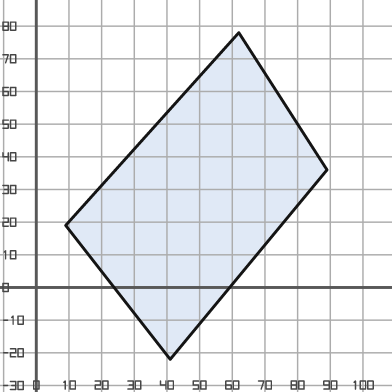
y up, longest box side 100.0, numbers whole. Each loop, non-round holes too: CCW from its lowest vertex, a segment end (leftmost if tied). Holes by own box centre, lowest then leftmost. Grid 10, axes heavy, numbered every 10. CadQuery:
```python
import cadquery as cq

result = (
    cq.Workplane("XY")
    .moveTo(41.0, -22.0)
    .lineTo(89.0, 36.0)
    .lineTo(62.0, 78.0)
    .lineTo(9.0, 19.0)
    .close()
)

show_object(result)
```